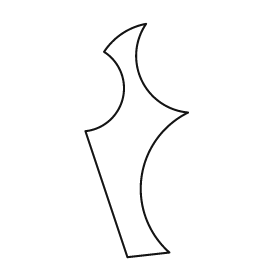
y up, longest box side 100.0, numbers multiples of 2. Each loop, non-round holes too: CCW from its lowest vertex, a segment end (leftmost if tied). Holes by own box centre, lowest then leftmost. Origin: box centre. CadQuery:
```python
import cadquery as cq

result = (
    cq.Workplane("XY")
    .moveTo(-4.0, -50.0)
    .lineTo(14.0, -48.0)
    .threePointArc((2.0, -16.0), (22.0, 12.0))
    .threePointArc((2.0, 26.0), (4.0, 50.0))
    .threePointArc((-6.0, 46.0), (-14.0, 38.0))
    .threePointArc((-6.0, 18.0), (-22.0, 4.0))
    .close()
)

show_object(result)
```